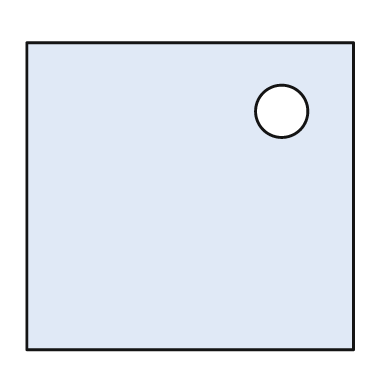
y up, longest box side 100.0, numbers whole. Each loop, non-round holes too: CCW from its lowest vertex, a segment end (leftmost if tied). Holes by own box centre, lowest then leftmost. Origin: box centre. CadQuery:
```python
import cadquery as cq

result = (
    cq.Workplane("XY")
    .moveTo(-50.0, -47.0)
    .lineTo(50.0, -47.0)
    .lineTo(50.0, 47.0)
    .lineTo(-50.0, 47.0)
    .close()
    .moveTo(28.0, 26.0)
    .circle(8.0)
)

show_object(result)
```